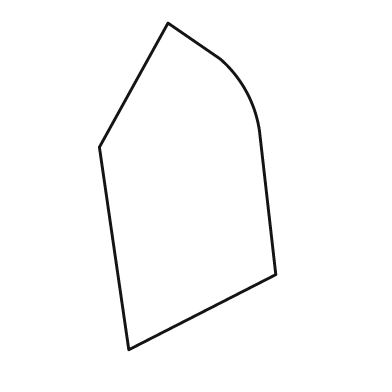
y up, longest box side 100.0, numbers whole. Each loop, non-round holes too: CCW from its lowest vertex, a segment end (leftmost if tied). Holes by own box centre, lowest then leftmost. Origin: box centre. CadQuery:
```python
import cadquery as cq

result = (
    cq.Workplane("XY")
    .moveTo(-18.0, -50.0)
    .lineTo(27.0, -27.0)
    .lineTo(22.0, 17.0)
    .threePointArc((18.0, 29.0), (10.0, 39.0))
    .lineTo(-6.0, 50.0)
    .lineTo(-27.0, 12.0)
    .close()
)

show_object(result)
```